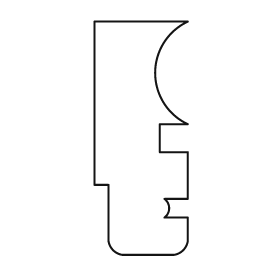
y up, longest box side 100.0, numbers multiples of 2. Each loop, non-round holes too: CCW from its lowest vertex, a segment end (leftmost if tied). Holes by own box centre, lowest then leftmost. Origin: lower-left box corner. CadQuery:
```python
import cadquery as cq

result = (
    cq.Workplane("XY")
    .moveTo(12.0, 0.0)
    .lineTo(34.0, 0.0)
    .threePointArc((38.0, 2.0), (40.0, 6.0))
    .lineTo(40.0, 16.0)
    .lineTo(30.0, 16.0)
    .threePointArc((32.0, 20.0), (30.0, 24.0))
    .lineTo(40.0, 24.0)
    .lineTo(40.0, 44.0)
    .lineTo(28.0, 44.0)
    .lineTo(28.0, 56.0)
    .lineTo(40.0, 56.0)
    .threePointArc((26.0, 78.0), (40.0, 100.0))
    .lineTo(0.0, 100.0)
    .lineTo(0.0, 30.0)
    .lineTo(6.0, 30.0)
    .lineTo(6.0, 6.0)
    .threePointArc((8.0, 2.0), (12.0, 0.0))
    .close()
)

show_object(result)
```